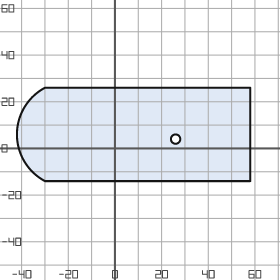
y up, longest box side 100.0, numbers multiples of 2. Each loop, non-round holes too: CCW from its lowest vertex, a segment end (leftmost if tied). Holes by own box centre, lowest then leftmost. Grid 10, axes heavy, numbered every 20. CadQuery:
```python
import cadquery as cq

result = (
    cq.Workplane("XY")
    .moveTo(-30.0, -14.0)
    .lineTo(58.0, -14.0)
    .lineTo(58.0, 26.0)
    .lineTo(-30.0, 26.0)
    .threePointArc((-42.0, 6.0), (-30.0, -14.0))
    .close()
    .moveTo(26.0, 4.0)
    .circle(2.0)
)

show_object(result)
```